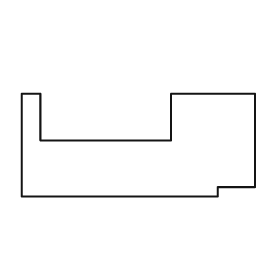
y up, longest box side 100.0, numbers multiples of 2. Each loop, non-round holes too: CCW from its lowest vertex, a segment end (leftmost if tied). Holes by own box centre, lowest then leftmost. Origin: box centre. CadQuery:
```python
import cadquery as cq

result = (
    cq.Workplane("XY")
    .moveTo(-50.0, -22.0)
    .lineTo(34.0, -22.0)
    .lineTo(34.0, -18.0)
    .lineTo(50.0, -18.0)
    .lineTo(50.0, 22.0)
    .lineTo(14.0, 22.0)
    .lineTo(14.0, 2.0)
    .lineTo(-42.0, 2.0)
    .lineTo(-42.0, 22.0)
    .lineTo(-50.0, 22.0)
    .close()
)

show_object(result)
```